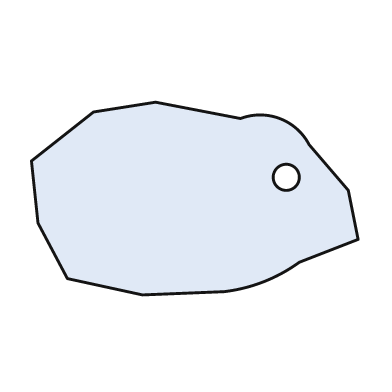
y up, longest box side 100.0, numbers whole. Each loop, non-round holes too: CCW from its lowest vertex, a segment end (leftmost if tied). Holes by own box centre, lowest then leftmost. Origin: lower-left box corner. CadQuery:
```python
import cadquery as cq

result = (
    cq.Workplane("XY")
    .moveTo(34.0, 0.0)
    .lineTo(59.0, 1.0)
    .threePointArc((71.0, 4.0), (82.0, 10.0))
    .lineTo(100.0, 17.0)
    .lineTo(97.0, 32.0)
    .lineTo(85.0, 46.0)
    .threePointArc((76.0, 54.0), (64.0, 54.0))
    .lineTo(38.0, 59.0)
    .lineTo(19.0, 56.0)
    .lineTo(0.0, 41.0)
    .lineTo(2.0, 22.0)
    .lineTo(11.0, 5.0)
    .close()
    .moveTo(78.0, 36.0)
    .circle(4.0)
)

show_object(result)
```